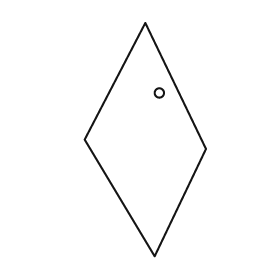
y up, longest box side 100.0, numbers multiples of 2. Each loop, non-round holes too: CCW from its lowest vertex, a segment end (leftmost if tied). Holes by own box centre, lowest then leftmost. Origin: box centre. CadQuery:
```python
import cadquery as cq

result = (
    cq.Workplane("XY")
    .moveTo(4.0, -50.0)
    .lineTo(26.0, -4.0)
    .lineTo(0.0, 50.0)
    .lineTo(-26.0, 0.0)
    .close()
    .moveTo(6.0, 20.0)
    .circle(2.0)
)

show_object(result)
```